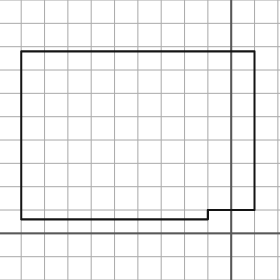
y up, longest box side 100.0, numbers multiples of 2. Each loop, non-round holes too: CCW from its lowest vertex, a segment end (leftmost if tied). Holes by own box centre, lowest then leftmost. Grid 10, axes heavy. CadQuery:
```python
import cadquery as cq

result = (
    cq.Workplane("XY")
    .moveTo(-90.0, 6.0)
    .lineTo(-10.0, 6.0)
    .lineTo(-10.0, 10.0)
    .lineTo(10.0, 10.0)
    .lineTo(10.0, 78.0)
    .lineTo(-90.0, 78.0)
    .close()
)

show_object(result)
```